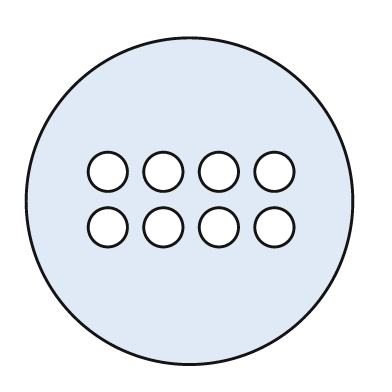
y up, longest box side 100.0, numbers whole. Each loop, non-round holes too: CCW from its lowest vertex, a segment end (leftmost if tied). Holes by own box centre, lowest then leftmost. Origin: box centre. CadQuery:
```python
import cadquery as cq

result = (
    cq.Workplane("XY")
    .moveTo(0.0, 0.0)
    .circle(50.0)
    .moveTo(-25.0, -8.0)
    .circle(6.0)
    .moveTo(-8.0, -8.0)
    .circle(6.0)
    .moveTo(9.0, -8.0)
    .circle(6.0)
    .moveTo(26.0, -8.0)
    .circle(6.0)
    .moveTo(-25.0, 9.0)
    .circle(6.0)
    .moveTo(-8.0, 9.0)
    .circle(6.0)
    .moveTo(9.0, 9.0)
    .circle(6.0)
    .moveTo(26.0, 9.0)
    .circle(6.0)
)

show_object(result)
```